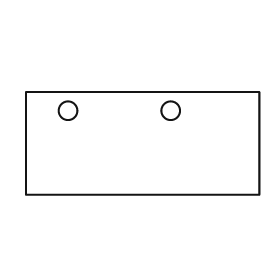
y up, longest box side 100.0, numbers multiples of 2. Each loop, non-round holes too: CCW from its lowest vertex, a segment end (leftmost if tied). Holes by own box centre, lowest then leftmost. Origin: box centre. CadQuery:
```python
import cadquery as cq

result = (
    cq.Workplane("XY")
    .moveTo(-50.0, -22.0)
    .lineTo(50.0, -22.0)
    .lineTo(50.0, 22.0)
    .lineTo(-50.0, 22.0)
    .close()
    .moveTo(-32.0, 14.0)
    .circle(4.0)
    .moveTo(12.0, 14.0)
    .circle(4.0)
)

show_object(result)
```